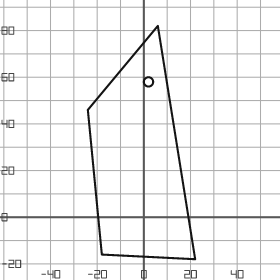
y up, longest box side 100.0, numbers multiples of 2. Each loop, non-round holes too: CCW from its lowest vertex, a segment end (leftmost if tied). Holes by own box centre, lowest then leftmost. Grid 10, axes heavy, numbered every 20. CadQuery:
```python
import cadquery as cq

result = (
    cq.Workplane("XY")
    .moveTo(22.0, -18.0)
    .lineTo(6.0, 82.0)
    .lineTo(-24.0, 46.0)
    .lineTo(-18.0, -16.0)
    .close()
    .moveTo(2.0, 58.0)
    .circle(2.0)
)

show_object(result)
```